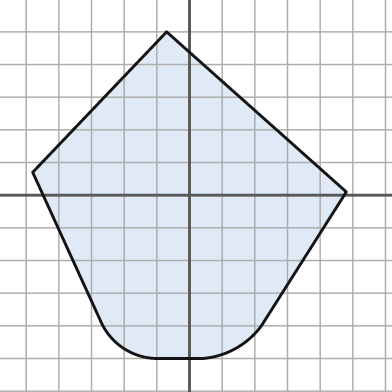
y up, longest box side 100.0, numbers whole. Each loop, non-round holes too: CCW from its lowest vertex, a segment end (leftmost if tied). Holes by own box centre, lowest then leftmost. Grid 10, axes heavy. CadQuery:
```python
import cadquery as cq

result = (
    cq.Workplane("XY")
    .moveTo(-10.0, -50.0)
    .lineTo(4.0, -50.0)
    .threePointArc((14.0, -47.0), (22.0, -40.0))
    .lineTo(48.0, 1.0)
    .lineTo(-7.0, 50.0)
    .lineTo(-48.0, 7.0)
    .lineTo(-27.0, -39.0)
    .threePointArc((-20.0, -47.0), (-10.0, -50.0))
    .close()
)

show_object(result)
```